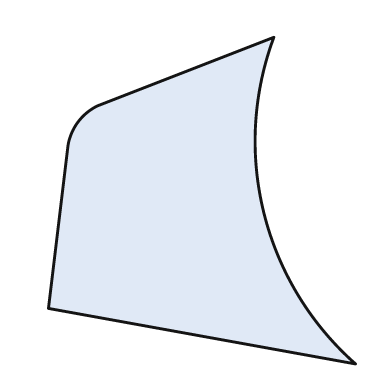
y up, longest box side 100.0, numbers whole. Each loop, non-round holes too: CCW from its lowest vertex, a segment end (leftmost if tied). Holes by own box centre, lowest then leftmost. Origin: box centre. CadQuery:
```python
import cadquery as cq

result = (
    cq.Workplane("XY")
    .moveTo(47.0, -50.0)
    .threePointArc((19.0, -4.0), (22.0, 50.0))
    .lineTo(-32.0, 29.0)
    .threePointArc((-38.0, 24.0), (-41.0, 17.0))
    .lineTo(-47.0, -33.0)
    .close()
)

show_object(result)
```